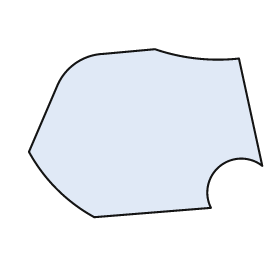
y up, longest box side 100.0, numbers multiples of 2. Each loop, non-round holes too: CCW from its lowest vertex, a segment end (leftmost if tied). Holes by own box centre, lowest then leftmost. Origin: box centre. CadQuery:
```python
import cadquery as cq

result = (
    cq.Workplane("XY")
    .moveTo(-22.0, -36.0)
    .lineTo(28.0, -32.0)
    .threePointArc((32.0, -14.0), (50.0, -14.0))
    .lineTo(40.0, 32.0)
    .threePointArc((22.0, 32.0), (4.0, 36.0))
    .lineTo(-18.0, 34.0)
    .threePointArc((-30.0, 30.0), (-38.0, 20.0))
    .lineTo(-50.0, -8.0)
    .threePointArc((-38.0, -24.0), (-22.0, -36.0))
    .close()
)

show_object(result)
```